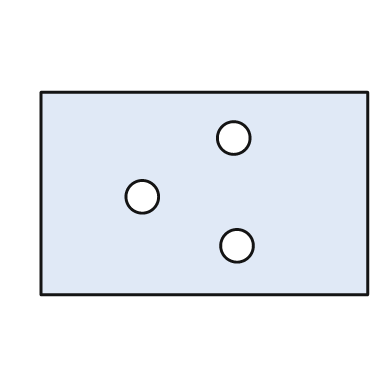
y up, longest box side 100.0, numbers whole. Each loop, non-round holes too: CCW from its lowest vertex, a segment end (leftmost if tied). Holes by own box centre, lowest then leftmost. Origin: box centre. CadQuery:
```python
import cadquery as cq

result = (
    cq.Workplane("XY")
    .moveTo(-50.0, -31.0)
    .lineTo(50.0, -31.0)
    .lineTo(50.0, 31.0)
    .lineTo(-50.0, 31.0)
    .close()
    .moveTo(10.0, -16.0)
    .circle(5.0)
    .moveTo(-19.0, -1.0)
    .circle(5.0)
    .moveTo(9.0, 17.0)
    .circle(5.0)
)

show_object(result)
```